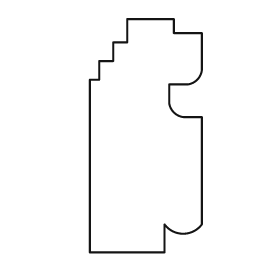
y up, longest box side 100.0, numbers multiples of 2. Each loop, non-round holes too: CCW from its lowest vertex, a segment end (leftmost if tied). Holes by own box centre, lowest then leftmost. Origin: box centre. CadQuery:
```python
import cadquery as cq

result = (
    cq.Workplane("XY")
    .moveTo(-24.0, -50.0)
    .lineTo(8.0, -50.0)
    .lineTo(8.0, -38.0)
    .threePointArc((16.0, -42.0), (24.0, -38.0))
    .lineTo(24.0, 8.0)
    .lineTo(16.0, 8.0)
    .threePointArc((12.0, 10.0), (10.0, 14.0))
    .lineTo(10.0, 22.0)
    .lineTo(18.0, 22.0)
    .threePointArc((22.0, 24.0), (24.0, 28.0))
    .lineTo(24.0, 44.0)
    .lineTo(12.0, 44.0)
    .lineTo(12.0, 50.0)
    .lineTo(-8.0, 50.0)
    .lineTo(-8.0, 40.0)
    .lineTo(-14.0, 40.0)
    .lineTo(-14.0, 32.0)
    .lineTo(-20.0, 32.0)
    .lineTo(-20.0, 24.0)
    .lineTo(-24.0, 24.0)
    .close()
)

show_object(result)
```